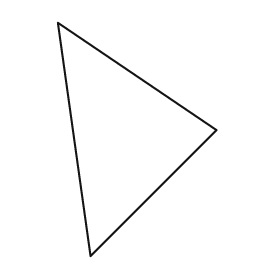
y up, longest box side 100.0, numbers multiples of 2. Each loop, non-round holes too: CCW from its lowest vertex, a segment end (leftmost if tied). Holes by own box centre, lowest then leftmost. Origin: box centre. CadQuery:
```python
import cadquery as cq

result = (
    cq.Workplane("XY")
    .moveTo(-20.0, -50.0)
    .lineTo(34.0, 4.0)
    .lineTo(-34.0, 50.0)
    .close()
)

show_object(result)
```